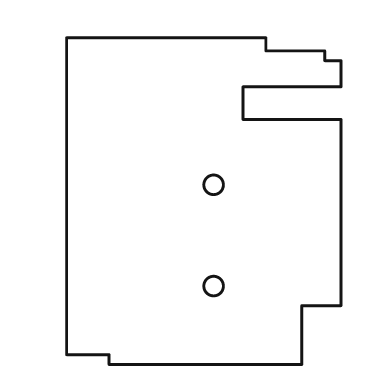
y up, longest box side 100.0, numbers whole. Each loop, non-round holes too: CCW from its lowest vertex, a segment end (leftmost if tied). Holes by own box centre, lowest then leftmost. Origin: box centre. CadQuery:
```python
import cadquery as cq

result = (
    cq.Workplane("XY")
    .moveTo(-29.0, -50.0)
    .lineTo(30.0, -50.0)
    .lineTo(30.0, -32.0)
    .lineTo(42.0, -32.0)
    .lineTo(42.0, 25.0)
    .lineTo(12.0, 25.0)
    .lineTo(12.0, 35.0)
    .lineTo(42.0, 35.0)
    .lineTo(42.0, 43.0)
    .lineTo(37.0, 43.0)
    .lineTo(37.0, 46.0)
    .lineTo(19.0, 46.0)
    .lineTo(19.0, 50.0)
    .lineTo(-42.0, 50.0)
    .lineTo(-42.0, -47.0)
    .lineTo(-29.0, -47.0)
    .close()
    .moveTo(3.0, -26.0)
    .circle(3.0)
    .moveTo(3.0, 5.0)
    .circle(3.0)
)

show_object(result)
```